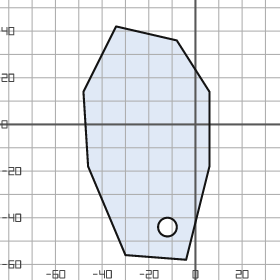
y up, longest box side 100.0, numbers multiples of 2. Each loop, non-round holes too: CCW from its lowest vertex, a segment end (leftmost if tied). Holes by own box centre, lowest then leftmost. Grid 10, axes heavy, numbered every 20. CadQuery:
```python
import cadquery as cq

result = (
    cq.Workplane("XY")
    .moveTo(-4.0, -58.0)
    .lineTo(6.0, -18.0)
    .lineTo(6.0, 14.0)
    .lineTo(-8.0, 36.0)
    .lineTo(-34.0, 42.0)
    .lineTo(-48.0, 14.0)
    .lineTo(-46.0, -18.0)
    .lineTo(-30.0, -56.0)
    .close()
    .moveTo(-12.0, -44.0)
    .circle(4.0)
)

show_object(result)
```